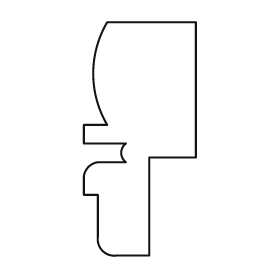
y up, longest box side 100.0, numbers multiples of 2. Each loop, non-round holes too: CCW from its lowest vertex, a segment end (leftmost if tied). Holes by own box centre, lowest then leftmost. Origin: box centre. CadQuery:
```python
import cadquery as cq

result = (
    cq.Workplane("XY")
    .moveTo(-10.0, -50.0)
    .lineTo(4.0, -50.0)
    .lineTo(4.0, -8.0)
    .lineTo(24.0, -8.0)
    .lineTo(24.0, 50.0)
    .lineTo(-14.0, 50.0)
    .threePointArc((-20.0, 28.0), (-14.0, 6.0))
    .lineTo(-24.0, 6.0)
    .lineTo(-24.0, -2.0)
    .lineTo(-6.0, -2.0)
    .threePointArc((-8.0, -6.0), (-6.0, -10.0))
    .lineTo(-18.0, -10.0)
    .threePointArc((-22.0, -12.0), (-24.0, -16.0))
    .lineTo(-24.0, -24.0)
    .lineTo(-18.0, -24.0)
    .lineTo(-18.0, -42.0)
    .threePointArc((-16.0, -48.0), (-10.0, -50.0))
    .close()
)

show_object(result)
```